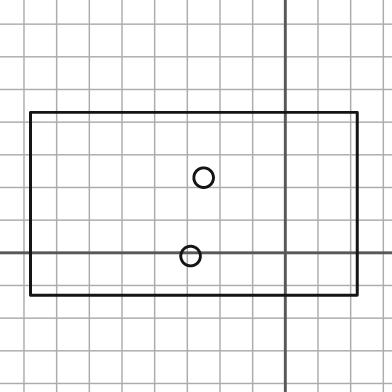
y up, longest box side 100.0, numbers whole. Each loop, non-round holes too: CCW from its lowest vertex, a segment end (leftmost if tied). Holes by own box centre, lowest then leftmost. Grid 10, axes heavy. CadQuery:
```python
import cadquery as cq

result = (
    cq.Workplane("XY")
    .moveTo(-78.0, -13.0)
    .lineTo(22.0, -13.0)
    .lineTo(22.0, 43.0)
    .lineTo(-78.0, 43.0)
    .close()
    .moveTo(-29.0, -1.0)
    .circle(3.0)
    .moveTo(-25.0, 23.0)
    .circle(3.0)
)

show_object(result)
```